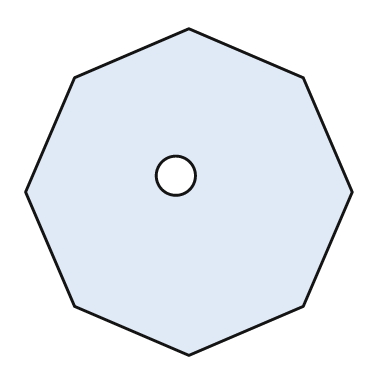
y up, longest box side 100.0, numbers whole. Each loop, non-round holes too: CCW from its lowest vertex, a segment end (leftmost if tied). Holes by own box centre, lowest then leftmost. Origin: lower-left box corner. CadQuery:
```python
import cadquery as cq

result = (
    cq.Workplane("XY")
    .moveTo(50.0, 0.0)
    .lineTo(85.0, 15.0)
    .lineTo(100.0, 50.0)
    .lineTo(85.0, 85.0)
    .lineTo(50.0, 100.0)
    .lineTo(15.0, 85.0)
    .lineTo(0.0, 50.0)
    .lineTo(15.0, 15.0)
    .close()
    .moveTo(46.0, 55.0)
    .circle(6.0)
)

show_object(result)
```